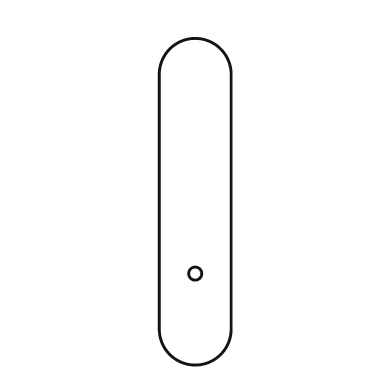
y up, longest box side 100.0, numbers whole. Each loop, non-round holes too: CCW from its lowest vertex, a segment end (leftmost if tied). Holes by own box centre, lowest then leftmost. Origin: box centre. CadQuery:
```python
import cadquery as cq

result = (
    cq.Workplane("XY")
    .moveTo(-11.0, -39.0)
    .threePointArc((0.0, -50.0), (11.0, -39.0))
    .lineTo(11.0, 39.0)
    .threePointArc((0.0, 50.0), (-11.0, 39.0))
    .close()
    .moveTo(0.0, -22.0)
    .circle(2.0)
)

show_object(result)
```